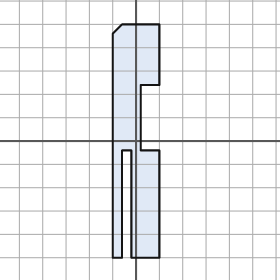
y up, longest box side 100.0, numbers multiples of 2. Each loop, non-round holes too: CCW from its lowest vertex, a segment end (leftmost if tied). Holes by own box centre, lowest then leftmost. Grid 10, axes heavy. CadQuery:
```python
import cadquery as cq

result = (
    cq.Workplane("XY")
    .moveTo(-10.0, -50.0)
    .lineTo(-6.0, -50.0)
    .lineTo(-6.0, -4.0)
    .lineTo(-2.0, -4.0)
    .lineTo(-2.0, -50.0)
    .lineTo(10.0, -50.0)
    .lineTo(10.0, -4.0)
    .lineTo(2.0, -4.0)
    .lineTo(2.0, 24.0)
    .lineTo(10.0, 24.0)
    .lineTo(10.0, 50.0)
    .lineTo(-6.0, 50.0)
    .lineTo(-10.0, 46.0)
    .close()
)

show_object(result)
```